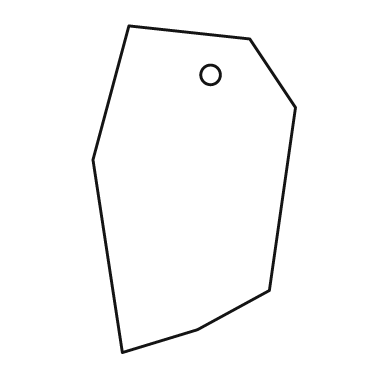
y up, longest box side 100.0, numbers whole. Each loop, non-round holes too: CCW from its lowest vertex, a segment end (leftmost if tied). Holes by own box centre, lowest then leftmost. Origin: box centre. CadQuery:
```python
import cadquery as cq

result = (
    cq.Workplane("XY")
    .moveTo(-22.0, -50.0)
    .lineTo(1.0, -43.0)
    .lineTo(23.0, -31.0)
    .lineTo(31.0, 25.0)
    .lineTo(17.0, 46.0)
    .lineTo(-20.0, 50.0)
    .lineTo(-31.0, 9.0)
    .close()
    .moveTo(5.0, 35.0)
    .circle(3.0)
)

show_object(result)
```